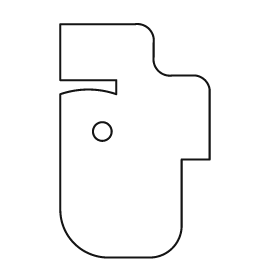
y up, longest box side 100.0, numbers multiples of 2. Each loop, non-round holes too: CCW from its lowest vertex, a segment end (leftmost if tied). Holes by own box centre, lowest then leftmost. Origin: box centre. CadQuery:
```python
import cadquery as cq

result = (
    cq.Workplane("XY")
    .moveTo(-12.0, -50.0)
    .lineTo(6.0, -50.0)
    .threePointArc((16.0, -46.0), (20.0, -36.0))
    .lineTo(20.0, -8.0)
    .lineTo(32.0, -8.0)
    .lineTo(32.0, 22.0)
    .threePointArc((30.0, 26.0), (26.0, 28.0))
    .lineTo(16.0, 28.0)
    .threePointArc((10.0, 30.0), (8.0, 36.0))
    .lineTo(8.0, 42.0)
    .threePointArc((6.0, 48.0), (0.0, 50.0))
    .lineTo(-32.0, 50.0)
    .lineTo(-32.0, 26.0)
    .lineTo(-8.0, 26.0)
    .lineTo(-8.0, 20.0)
    .threePointArc((-20.0, 22.0), (-32.0, 20.0))
    .lineTo(-32.0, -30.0)
    .threePointArc((-26.0, -44.0), (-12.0, -50.0))
    .close()
    .moveTo(-14.0, 4.0)
    .circle(4.0)
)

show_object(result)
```